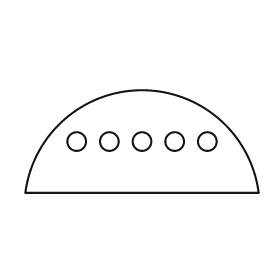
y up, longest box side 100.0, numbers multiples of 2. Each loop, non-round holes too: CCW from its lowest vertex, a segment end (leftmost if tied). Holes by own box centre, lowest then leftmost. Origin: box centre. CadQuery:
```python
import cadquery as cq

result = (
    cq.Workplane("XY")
    .moveTo(-50.0, -22.0)
    .lineTo(50.0, -22.0)
    .threePointArc((0.0, 22.0), (-50.0, -22.0))
    .close()
    .moveTo(-28.0, 0.0)
    .circle(4.0)
    .moveTo(-14.0, 0.0)
    .circle(4.0)
    .moveTo(0.0, 0.0)
    .circle(4.0)
    .moveTo(14.0, 0.0)
    .circle(4.0)
    .moveTo(28.0, 0.0)
    .circle(4.0)
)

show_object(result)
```